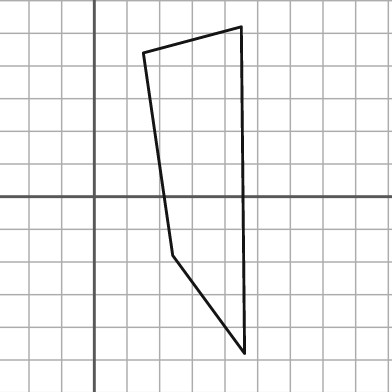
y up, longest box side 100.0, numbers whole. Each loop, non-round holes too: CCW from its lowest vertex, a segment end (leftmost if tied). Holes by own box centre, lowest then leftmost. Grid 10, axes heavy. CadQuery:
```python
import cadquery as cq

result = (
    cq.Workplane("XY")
    .moveTo(46.0, -48.0)
    .lineTo(45.0, 52.0)
    .lineTo(15.0, 44.0)
    .lineTo(24.0, -18.0)
    .close()
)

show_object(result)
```